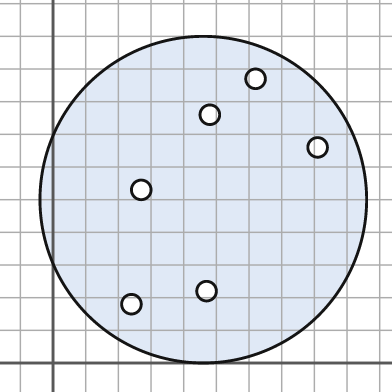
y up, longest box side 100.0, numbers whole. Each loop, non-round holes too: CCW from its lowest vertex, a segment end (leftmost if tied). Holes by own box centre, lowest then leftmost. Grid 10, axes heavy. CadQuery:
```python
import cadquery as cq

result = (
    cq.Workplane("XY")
    .moveTo(46.0, 50.0)
    .circle(50.0)
    .moveTo(24.0, 18.0)
    .circle(3.0)
    .moveTo(47.0, 22.0)
    .circle(3.0)
    .moveTo(27.0, 53.0)
    .circle(3.0)
    .moveTo(81.0, 66.0)
    .circle(3.0)
    .moveTo(48.0, 76.0)
    .circle(3.0)
    .moveTo(62.0, 87.0)
    .circle(3.0)
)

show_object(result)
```